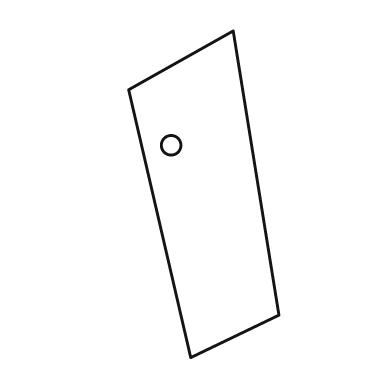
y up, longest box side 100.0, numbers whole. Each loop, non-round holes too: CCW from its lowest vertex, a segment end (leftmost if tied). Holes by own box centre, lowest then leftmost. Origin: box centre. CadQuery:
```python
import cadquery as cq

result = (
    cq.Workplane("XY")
    .moveTo(-4.0, -50.0)
    .lineTo(23.0, -37.0)
    .lineTo(9.0, 50.0)
    .lineTo(-23.0, 32.0)
    .close()
    .moveTo(-10.0, 15.0)
    .circle(3.0)
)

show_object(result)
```